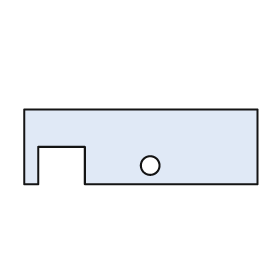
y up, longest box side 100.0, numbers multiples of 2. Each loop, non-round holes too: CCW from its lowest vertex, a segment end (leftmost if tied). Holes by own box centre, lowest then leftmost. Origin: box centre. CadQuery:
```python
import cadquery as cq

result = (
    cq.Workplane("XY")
    .moveTo(-50.0, -16.0)
    .lineTo(-44.0, -16.0)
    .lineTo(-44.0, 0.0)
    .lineTo(-24.0, 0.0)
    .lineTo(-24.0, -16.0)
    .lineTo(50.0, -16.0)
    .lineTo(50.0, 16.0)
    .lineTo(-50.0, 16.0)
    .close()
    .moveTo(4.0, -8.0)
    .circle(4.0)
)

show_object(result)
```